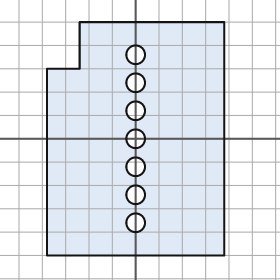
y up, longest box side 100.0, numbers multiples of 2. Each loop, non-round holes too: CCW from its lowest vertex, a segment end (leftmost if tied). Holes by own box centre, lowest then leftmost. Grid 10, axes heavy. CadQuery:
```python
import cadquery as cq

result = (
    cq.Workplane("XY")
    .moveTo(-38.0, -50.0)
    .lineTo(38.0, -50.0)
    .lineTo(38.0, 50.0)
    .lineTo(-24.0, 50.0)
    .lineTo(-24.0, 30.0)
    .lineTo(-38.0, 30.0)
    .close()
    .moveTo(0.0, -36.0)
    .circle(4.0)
    .moveTo(0.0, -24.0)
    .circle(4.0)
    .moveTo(0.0, -12.0)
    .circle(4.0)
    .moveTo(0.0, 0.0)
    .circle(4.0)
    .moveTo(0.0, 12.0)
    .circle(4.0)
    .moveTo(0.0, 24.0)
    .circle(4.0)
    .moveTo(0.0, 36.0)
    .circle(4.0)
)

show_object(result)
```